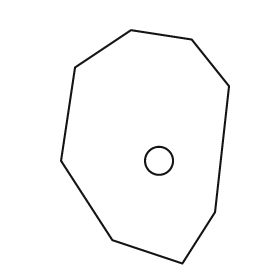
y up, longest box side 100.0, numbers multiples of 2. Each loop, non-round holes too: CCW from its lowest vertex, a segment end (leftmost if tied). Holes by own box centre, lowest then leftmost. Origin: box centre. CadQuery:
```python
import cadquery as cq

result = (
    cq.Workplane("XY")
    .moveTo(16.0, -50.0)
    .lineTo(30.0, -28.0)
    .lineTo(36.0, 26.0)
    .lineTo(20.0, 46.0)
    .lineTo(-6.0, 50.0)
    .lineTo(-30.0, 34.0)
    .lineTo(-36.0, -6.0)
    .lineTo(-14.0, -40.0)
    .close()
    .moveTo(6.0, -6.0)
    .circle(6.0)
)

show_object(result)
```